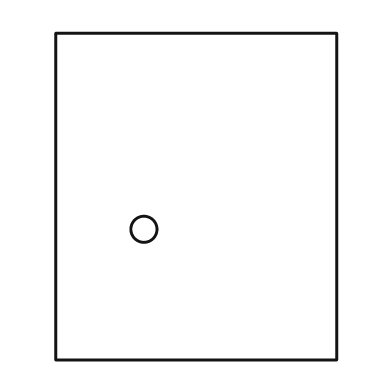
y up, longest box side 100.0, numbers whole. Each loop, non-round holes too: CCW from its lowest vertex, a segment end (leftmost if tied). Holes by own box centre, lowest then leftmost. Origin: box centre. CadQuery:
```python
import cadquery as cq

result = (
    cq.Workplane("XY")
    .moveTo(-43.0, -50.0)
    .lineTo(43.0, -50.0)
    .lineTo(43.0, 50.0)
    .lineTo(-43.0, 50.0)
    .close()
    .moveTo(-16.0, -10.0)
    .circle(4.0)
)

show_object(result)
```